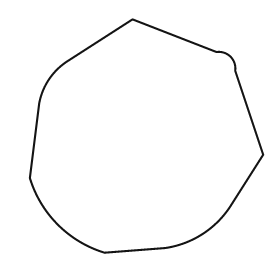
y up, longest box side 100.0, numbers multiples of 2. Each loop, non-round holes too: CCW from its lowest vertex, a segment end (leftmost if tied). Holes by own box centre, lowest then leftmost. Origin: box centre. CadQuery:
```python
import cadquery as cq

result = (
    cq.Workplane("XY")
    .moveTo(-18.0, -50.0)
    .lineTo(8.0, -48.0)
    .threePointArc((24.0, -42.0), (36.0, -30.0))
    .lineTo(50.0, -8.0)
    .lineTo(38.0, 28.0)
    .threePointArc((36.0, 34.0), (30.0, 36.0))
    .lineTo(-6.0, 50.0)
    .lineTo(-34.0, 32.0)
    .threePointArc((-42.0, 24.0), (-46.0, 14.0))
    .lineTo(-50.0, -18.0)
    .threePointArc((-38.0, -38.0), (-18.0, -50.0))
    .close()
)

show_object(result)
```